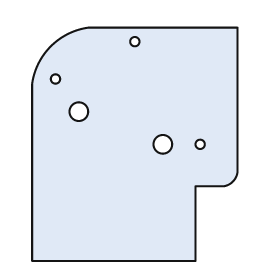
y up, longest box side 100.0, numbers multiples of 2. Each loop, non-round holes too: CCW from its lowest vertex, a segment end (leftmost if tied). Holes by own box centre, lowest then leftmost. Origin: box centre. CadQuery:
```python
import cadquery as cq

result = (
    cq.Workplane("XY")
    .moveTo(-44.0, -50.0)
    .lineTo(26.0, -50.0)
    .lineTo(26.0, -18.0)
    .lineTo(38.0, -18.0)
    .threePointArc((42.0, -16.0), (44.0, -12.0))
    .lineTo(44.0, 50.0)
    .lineTo(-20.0, 50.0)
    .threePointArc((-36.0, 42.0), (-44.0, 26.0))
    .close()
    .moveTo(12.0, 0.0)
    .circle(4.0)
    .moveTo(28.0, 0.0)
    .circle(2.0)
    .moveTo(-24.0, 14.0)
    .circle(4.0)
    .moveTo(-34.0, 28.0)
    .circle(2.0)
    .moveTo(0.0, 44.0)
    .circle(2.0)
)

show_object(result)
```